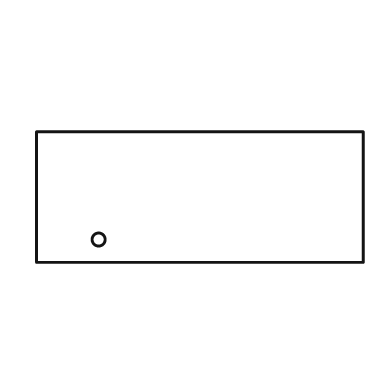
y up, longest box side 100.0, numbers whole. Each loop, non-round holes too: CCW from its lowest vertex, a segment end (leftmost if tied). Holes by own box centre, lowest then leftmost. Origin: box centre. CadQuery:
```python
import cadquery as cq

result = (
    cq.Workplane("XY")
    .moveTo(-50.0, -20.0)
    .lineTo(50.0, -20.0)
    .lineTo(50.0, 20.0)
    .lineTo(-50.0, 20.0)
    .close()
    .moveTo(-31.0, -13.0)
    .circle(2.0)
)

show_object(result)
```